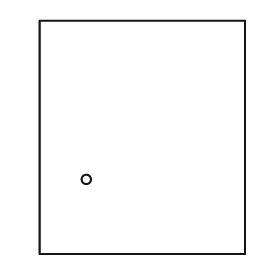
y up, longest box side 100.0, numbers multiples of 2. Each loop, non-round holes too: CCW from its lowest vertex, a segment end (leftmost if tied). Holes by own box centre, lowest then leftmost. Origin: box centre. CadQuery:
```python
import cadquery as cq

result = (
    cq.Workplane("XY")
    .moveTo(-44.0, -50.0)
    .lineTo(44.0, -50.0)
    .lineTo(44.0, 50.0)
    .lineTo(-44.0, 50.0)
    .close()
    .moveTo(-24.0, -18.0)
    .circle(2.0)
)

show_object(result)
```